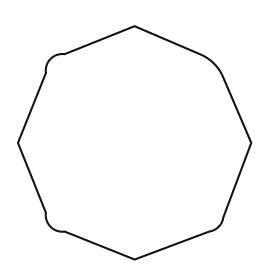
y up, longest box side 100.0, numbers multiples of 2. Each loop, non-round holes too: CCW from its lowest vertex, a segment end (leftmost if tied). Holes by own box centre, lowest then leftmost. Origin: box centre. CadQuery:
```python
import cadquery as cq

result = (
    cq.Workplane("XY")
    .moveTo(0.0, -50.0)
    .lineTo(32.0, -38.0)
    .threePointArc((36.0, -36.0), (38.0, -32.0))
    .lineTo(50.0, 0.0)
    .lineTo(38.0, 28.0)
    .threePointArc((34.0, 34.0), (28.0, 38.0))
    .lineTo(0.0, 50.0)
    .lineTo(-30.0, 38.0)
    .threePointArc((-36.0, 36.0), (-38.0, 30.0))
    .lineTo(-50.0, 0.0)
    .lineTo(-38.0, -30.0)
    .threePointArc((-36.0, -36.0), (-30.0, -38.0))
    .close()
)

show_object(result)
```